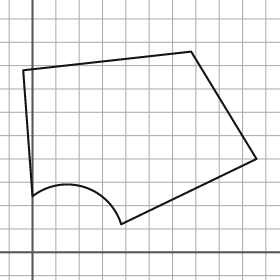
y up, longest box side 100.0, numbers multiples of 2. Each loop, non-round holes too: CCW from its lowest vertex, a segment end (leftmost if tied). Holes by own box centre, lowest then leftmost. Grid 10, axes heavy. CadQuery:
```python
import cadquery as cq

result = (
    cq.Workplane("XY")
    .moveTo(38.0, 12.0)
    .lineTo(96.0, 40.0)
    .lineTo(68.0, 86.0)
    .lineTo(-4.0, 78.0)
    .lineTo(0.0, 24.0)
    .threePointArc((22.0, 28.0), (38.0, 12.0))
    .close()
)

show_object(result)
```